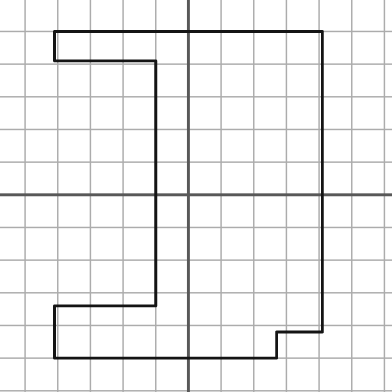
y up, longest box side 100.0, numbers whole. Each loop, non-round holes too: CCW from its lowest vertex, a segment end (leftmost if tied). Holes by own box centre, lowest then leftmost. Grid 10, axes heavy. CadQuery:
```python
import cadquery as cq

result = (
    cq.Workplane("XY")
    .moveTo(-41.0, -50.0)
    .lineTo(27.0, -50.0)
    .lineTo(27.0, -42.0)
    .lineTo(41.0, -42.0)
    .lineTo(41.0, 50.0)
    .lineTo(-41.0, 50.0)
    .lineTo(-41.0, 41.0)
    .lineTo(-10.0, 41.0)
    .lineTo(-10.0, -34.0)
    .lineTo(-41.0, -34.0)
    .close()
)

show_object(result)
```